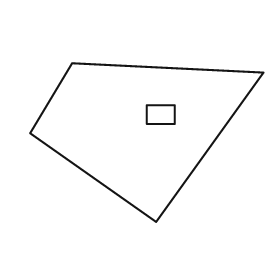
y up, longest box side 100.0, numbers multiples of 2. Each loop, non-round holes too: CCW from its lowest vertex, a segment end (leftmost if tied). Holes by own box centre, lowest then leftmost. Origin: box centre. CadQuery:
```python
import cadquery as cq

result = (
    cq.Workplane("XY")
    .moveTo(4.0, -34.0)
    .lineTo(50.0, 30.0)
    .lineTo(-32.0, 34.0)
    .lineTo(-50.0, 4.0)
    .close()
    .moveTo(0.0, 8.0)
    .lineTo(12.0, 8.0)
    .lineTo(12.0, 16.0)
    .lineTo(0.0, 16.0)
    .close()
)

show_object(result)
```